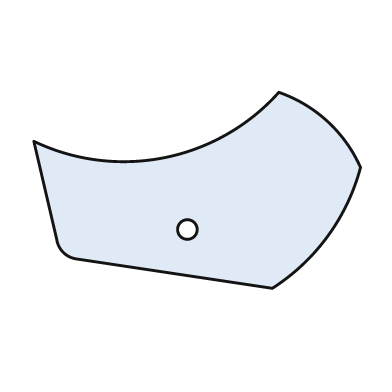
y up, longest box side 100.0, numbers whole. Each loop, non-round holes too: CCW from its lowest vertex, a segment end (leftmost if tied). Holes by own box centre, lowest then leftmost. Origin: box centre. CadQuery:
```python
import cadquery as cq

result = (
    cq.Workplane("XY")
    .moveTo(23.0, -30.0)
    .threePointArc((40.0, -14.0), (50.0, 7.0))
    .threePointArc((40.0, 21.0), (25.0, 30.0))
    .threePointArc((-10.0, 10.0), (-50.0, 15.0))
    .lineTo(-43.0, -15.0)
    .threePointArc((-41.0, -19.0), (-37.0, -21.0))
    .close()
    .moveTo(-3.0, -12.0)
    .circle(3.0)
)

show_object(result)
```